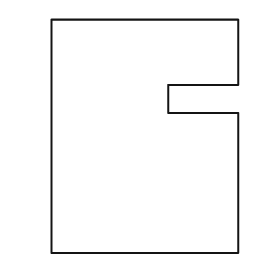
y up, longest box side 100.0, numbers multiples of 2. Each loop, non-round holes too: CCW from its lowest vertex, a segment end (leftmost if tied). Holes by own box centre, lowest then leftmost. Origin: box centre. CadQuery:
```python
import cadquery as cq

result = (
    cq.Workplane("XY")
    .moveTo(-40.0, -50.0)
    .lineTo(40.0, -50.0)
    .lineTo(40.0, 10.0)
    .lineTo(10.0, 10.0)
    .lineTo(10.0, 22.0)
    .lineTo(40.0, 22.0)
    .lineTo(40.0, 50.0)
    .lineTo(-40.0, 50.0)
    .close()
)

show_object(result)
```